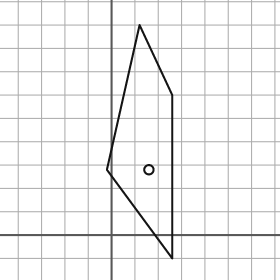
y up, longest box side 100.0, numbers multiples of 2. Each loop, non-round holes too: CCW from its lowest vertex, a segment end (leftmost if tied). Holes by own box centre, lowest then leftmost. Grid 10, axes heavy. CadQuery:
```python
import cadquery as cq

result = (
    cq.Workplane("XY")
    .moveTo(26.0, -10.0)
    .lineTo(26.0, 60.0)
    .lineTo(12.0, 90.0)
    .lineTo(-2.0, 28.0)
    .close()
    .moveTo(16.0, 28.0)
    .circle(2.0)
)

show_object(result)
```